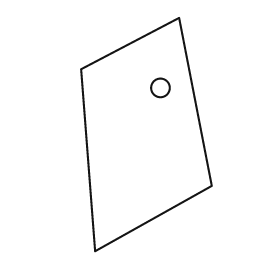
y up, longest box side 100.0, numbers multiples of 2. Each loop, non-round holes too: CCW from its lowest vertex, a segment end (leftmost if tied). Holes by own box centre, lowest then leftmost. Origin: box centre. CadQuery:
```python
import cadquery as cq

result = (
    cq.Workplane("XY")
    .moveTo(-22.0, -50.0)
    .lineTo(28.0, -22.0)
    .lineTo(14.0, 50.0)
    .lineTo(-28.0, 28.0)
    .close()
    .moveTo(6.0, 20.0)
    .circle(4.0)
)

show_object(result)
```